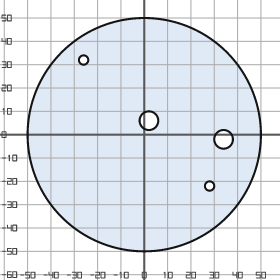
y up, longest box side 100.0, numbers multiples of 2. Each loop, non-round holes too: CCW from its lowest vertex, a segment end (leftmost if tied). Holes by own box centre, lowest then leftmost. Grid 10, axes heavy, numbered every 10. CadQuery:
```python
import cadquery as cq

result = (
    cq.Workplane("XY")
    .moveTo(0.0, 0.0)
    .circle(50.0)
    .moveTo(28.0, -22.0)
    .circle(2.0)
    .moveTo(34.0, -2.0)
    .circle(4.0)
    .moveTo(2.0, 6.0)
    .circle(4.0)
    .moveTo(-26.0, 32.0)
    .circle(2.0)
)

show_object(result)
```